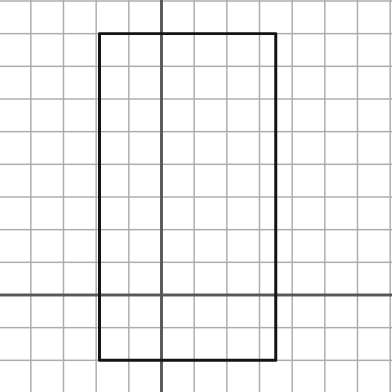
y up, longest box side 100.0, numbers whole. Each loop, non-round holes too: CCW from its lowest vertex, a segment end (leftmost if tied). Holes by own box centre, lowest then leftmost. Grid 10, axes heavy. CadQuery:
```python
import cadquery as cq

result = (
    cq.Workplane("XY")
    .moveTo(-19.0, -20.0)
    .lineTo(35.0, -20.0)
    .lineTo(35.0, 80.0)
    .lineTo(-19.0, 80.0)
    .close()
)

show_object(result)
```